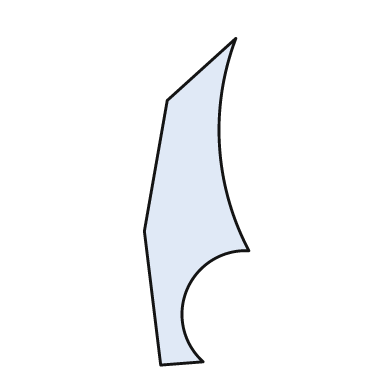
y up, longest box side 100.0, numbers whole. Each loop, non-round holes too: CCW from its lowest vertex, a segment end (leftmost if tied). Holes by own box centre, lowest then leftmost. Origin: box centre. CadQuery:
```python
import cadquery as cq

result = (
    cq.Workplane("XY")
    .moveTo(-11.0, -50.0)
    .lineTo(2.0, -49.0)
    .threePointArc((-3.0, -27.0), (16.0, -15.0))
    .threePointArc((7.0, 17.0), (12.0, 50.0))
    .lineTo(-9.0, 31.0)
    .lineTo(-16.0, -9.0)
    .close()
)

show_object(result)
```